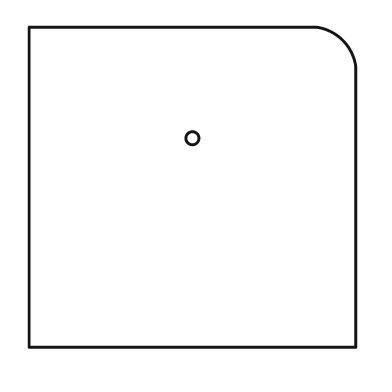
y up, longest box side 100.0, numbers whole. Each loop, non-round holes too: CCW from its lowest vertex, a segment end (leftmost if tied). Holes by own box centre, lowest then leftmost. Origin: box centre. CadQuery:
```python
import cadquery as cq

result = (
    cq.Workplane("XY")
    .moveTo(-50.0, -49.0)
    .lineTo(50.0, -49.0)
    .lineTo(50.0, 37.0)
    .threePointArc((46.0, 45.0), (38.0, 49.0))
    .lineTo(-50.0, 49.0)
    .close()
    .moveTo(0.0, 15.0)
    .circle(2.0)
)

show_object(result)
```